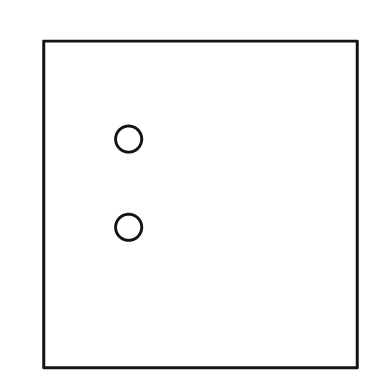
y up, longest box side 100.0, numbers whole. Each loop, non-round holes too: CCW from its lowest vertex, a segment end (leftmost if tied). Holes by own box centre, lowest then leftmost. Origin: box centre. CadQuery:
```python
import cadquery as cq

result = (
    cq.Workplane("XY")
    .moveTo(-48.0, -50.0)
    .lineTo(48.0, -50.0)
    .lineTo(48.0, 50.0)
    .lineTo(-48.0, 50.0)
    .close()
    .moveTo(-22.0, -7.0)
    .circle(4.0)
    .moveTo(-22.0, 20.0)
    .circle(4.0)
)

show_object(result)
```